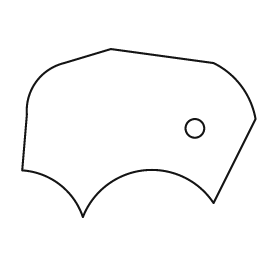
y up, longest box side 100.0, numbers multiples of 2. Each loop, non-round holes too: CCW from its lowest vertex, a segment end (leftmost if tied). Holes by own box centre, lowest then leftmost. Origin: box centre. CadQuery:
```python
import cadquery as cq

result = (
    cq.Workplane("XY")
    .moveTo(-24.0, -36.0)
    .threePointArc((2.0, -16.0), (32.0, -30.0))
    .lineTo(50.0, 6.0)
    .threePointArc((44.0, 20.0), (32.0, 30.0))
    .lineTo(-12.0, 36.0)
    .lineTo(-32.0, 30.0)
    .threePointArc((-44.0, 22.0), (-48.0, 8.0))
    .lineTo(-50.0, -16.0)
    .threePointArc((-34.0, -22.0), (-24.0, -36.0))
    .close()
    .moveTo(24.0, 2.0)
    .circle(4.0)
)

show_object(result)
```